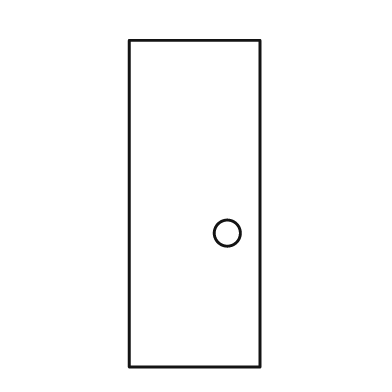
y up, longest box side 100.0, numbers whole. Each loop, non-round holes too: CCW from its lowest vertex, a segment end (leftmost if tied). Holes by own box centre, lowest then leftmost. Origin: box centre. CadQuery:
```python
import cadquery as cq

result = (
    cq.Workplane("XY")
    .moveTo(-20.0, -50.0)
    .lineTo(20.0, -50.0)
    .lineTo(20.0, 50.0)
    .lineTo(-20.0, 50.0)
    .close()
    .moveTo(10.0, -9.0)
    .circle(4.0)
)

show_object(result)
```